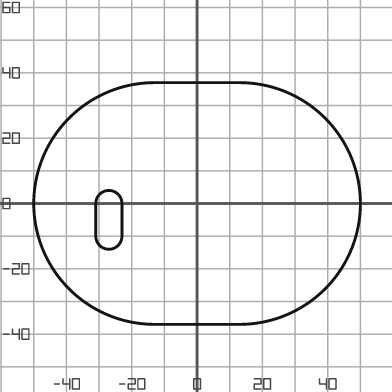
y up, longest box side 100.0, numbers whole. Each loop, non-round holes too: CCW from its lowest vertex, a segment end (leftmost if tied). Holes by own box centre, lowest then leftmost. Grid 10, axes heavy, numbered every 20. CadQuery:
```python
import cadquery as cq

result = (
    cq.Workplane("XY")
    .moveTo(-13.0, -37.0)
    .lineTo(13.0, -37.0)
    .threePointArc((50.0, 0.0), (13.0, 37.0))
    .lineTo(-13.0, 37.0)
    .threePointArc((-50.0, 0.0), (-13.0, -37.0))
    .close()
    .moveTo(-31.0, -10.0)
    .threePointArc((-27.0, -14.0), (-23.0, -10.0))
    .lineTo(-23.0, 0.0)
    .threePointArc((-27.0, 4.0), (-31.0, 0.0))
    .close()
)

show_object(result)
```